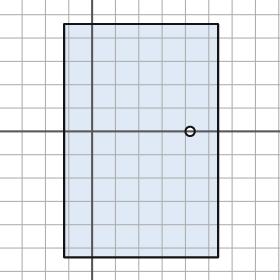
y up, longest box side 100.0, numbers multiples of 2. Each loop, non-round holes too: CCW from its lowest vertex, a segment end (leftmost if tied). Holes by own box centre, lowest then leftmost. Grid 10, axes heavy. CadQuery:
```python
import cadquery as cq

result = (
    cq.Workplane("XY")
    .moveTo(-12.0, -54.0)
    .lineTo(54.0, -54.0)
    .lineTo(54.0, 46.0)
    .lineTo(-12.0, 46.0)
    .close()
    .moveTo(42.0, 0.0)
    .circle(2.0)
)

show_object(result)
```